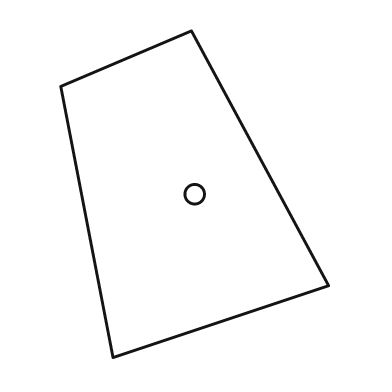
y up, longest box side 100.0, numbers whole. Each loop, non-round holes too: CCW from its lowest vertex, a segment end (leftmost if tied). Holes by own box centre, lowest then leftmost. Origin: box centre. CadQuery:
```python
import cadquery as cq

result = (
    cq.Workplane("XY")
    .moveTo(-25.0, -50.0)
    .lineTo(41.0, -28.0)
    .lineTo(-1.0, 50.0)
    .lineTo(-41.0, 33.0)
    .close()
    .moveTo(0.0, 0.0)
    .circle(3.0)
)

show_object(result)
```